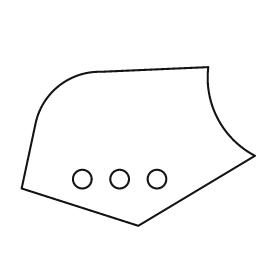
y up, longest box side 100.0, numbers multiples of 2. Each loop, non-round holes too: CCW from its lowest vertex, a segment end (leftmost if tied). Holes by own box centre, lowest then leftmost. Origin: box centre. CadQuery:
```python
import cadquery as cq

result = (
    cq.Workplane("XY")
    .moveTo(0.0, -34.0)
    .lineTo(50.0, -4.0)
    .threePointArc((34.0, 12.0), (30.0, 34.0))
    .lineTo(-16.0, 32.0)
    .threePointArc((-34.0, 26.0), (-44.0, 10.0))
    .lineTo(-50.0, -18.0)
    .close()
    .moveTo(-24.0, -14.0)
    .circle(4.0)
    .moveTo(-8.0, -14.0)
    .circle(4.0)
    .moveTo(8.0, -14.0)
    .circle(4.0)
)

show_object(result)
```